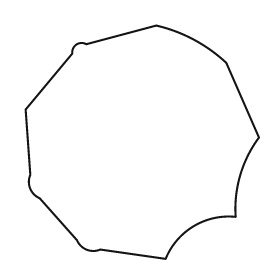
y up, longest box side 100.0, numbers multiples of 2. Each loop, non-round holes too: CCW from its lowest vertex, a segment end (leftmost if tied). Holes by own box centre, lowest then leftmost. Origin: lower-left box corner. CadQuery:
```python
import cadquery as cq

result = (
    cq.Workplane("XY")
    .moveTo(60.0, 0.0)
    .threePointArc((72.0, 14.0), (90.0, 18.0))
    .threePointArc((92.0, 36.0), (100.0, 52.0))
    .lineTo(86.0, 84.0)
    .threePointArc((72.0, 94.0), (56.0, 100.0))
    .lineTo(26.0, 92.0)
    .threePointArc((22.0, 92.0), (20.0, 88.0))
    .lineTo(0.0, 64.0)
    .lineTo(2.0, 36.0)
    .threePointArc((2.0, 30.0), (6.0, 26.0))
    .lineTo(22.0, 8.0)
    .threePointArc((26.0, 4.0), (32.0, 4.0))
    .close()
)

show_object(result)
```